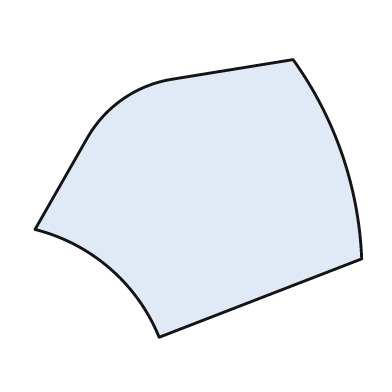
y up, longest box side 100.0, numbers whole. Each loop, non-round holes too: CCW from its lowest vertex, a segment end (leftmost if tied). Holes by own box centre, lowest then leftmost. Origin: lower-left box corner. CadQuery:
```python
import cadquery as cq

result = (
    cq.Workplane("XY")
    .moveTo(38.0, 0.0)
    .lineTo(100.0, 24.0)
    .threePointArc((94.0, 56.0), (79.0, 85.0))
    .lineTo(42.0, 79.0)
    .threePointArc((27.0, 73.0), (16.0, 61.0))
    .lineTo(0.0, 33.0)
    .threePointArc((23.0, 21.0), (38.0, 0.0))
    .close()
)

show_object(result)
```